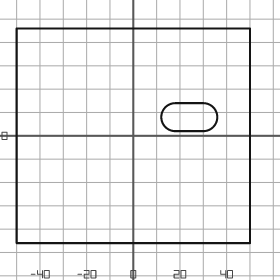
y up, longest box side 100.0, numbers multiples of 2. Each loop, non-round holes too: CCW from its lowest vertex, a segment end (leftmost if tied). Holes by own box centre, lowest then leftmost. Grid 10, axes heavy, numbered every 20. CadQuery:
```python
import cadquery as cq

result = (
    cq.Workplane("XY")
    .moveTo(-50.0, -46.0)
    .lineTo(50.0, -46.0)
    .lineTo(50.0, 46.0)
    .lineTo(-50.0, 46.0)
    .close()
    .moveTo(18.0, 2.0)
    .lineTo(30.0, 2.0)
    .threePointArc((36.0, 8.0), (30.0, 14.0))
    .lineTo(18.0, 14.0)
    .threePointArc((12.0, 8.0), (18.0, 2.0))
    .close()
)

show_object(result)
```